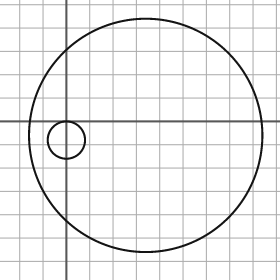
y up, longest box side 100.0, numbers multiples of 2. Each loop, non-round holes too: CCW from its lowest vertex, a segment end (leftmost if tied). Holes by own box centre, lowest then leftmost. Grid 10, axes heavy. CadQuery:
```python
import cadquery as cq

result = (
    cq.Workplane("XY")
    .moveTo(34.0, -6.0)
    .circle(50.0)
    .moveTo(0.0, -8.0)
    .circle(8.0)
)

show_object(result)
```